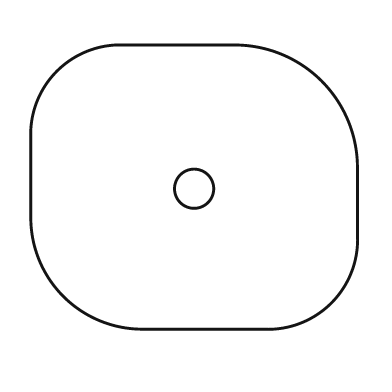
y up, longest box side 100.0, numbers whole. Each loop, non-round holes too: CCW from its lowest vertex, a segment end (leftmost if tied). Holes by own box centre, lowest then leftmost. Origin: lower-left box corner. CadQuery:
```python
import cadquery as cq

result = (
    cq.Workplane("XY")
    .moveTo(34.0, 0.0)
    .lineTo(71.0, 0.0)
    .threePointArc((92.0, 8.0), (100.0, 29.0))
    .lineTo(100.0, 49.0)
    .threePointArc((89.0, 76.0), (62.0, 87.0))
    .lineTo(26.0, 87.0)
    .threePointArc((8.0, 79.0), (0.0, 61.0))
    .lineTo(0.0, 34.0)
    .threePointArc((10.0, 10.0), (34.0, 0.0))
    .close()
    .moveTo(50.0, 43.0)
    .circle(6.0)
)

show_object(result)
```